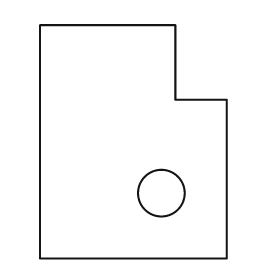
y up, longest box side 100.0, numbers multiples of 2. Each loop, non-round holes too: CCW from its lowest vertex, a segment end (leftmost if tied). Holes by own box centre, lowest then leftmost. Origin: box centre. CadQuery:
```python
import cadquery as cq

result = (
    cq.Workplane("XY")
    .moveTo(-40.0, -50.0)
    .lineTo(40.0, -50.0)
    .lineTo(40.0, 18.0)
    .lineTo(18.0, 18.0)
    .lineTo(18.0, 50.0)
    .lineTo(-40.0, 50.0)
    .close()
    .moveTo(12.0, -22.0)
    .circle(10.0)
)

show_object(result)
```